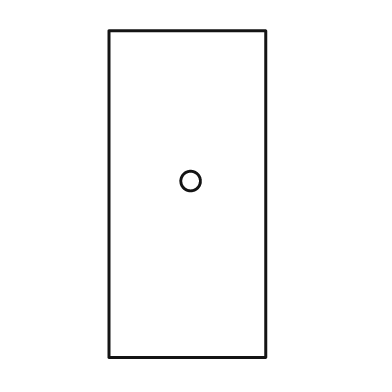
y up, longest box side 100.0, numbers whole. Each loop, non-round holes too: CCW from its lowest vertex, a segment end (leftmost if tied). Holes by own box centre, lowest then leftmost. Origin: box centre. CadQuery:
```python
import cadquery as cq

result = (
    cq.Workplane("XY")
    .moveTo(-24.0, -50.0)
    .lineTo(24.0, -50.0)
    .lineTo(24.0, 50.0)
    .lineTo(-24.0, 50.0)
    .close()
    .moveTo(1.0, 4.0)
    .circle(3.0)
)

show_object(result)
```